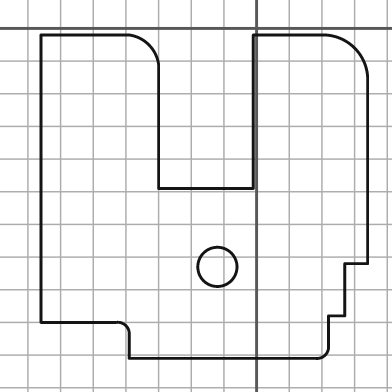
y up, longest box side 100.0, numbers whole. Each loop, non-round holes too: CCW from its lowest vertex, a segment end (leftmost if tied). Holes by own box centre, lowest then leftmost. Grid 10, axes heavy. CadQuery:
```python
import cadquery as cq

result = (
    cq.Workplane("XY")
    .moveTo(-39.0, -101.0)
    .lineTo(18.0, -101.0)
    .threePointArc((21.0, -100.0), (22.0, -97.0))
    .lineTo(22.0, -88.0)
    .lineTo(27.0, -88.0)
    .lineTo(27.0, -72.0)
    .lineTo(34.0, -72.0)
    .lineTo(34.0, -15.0)
    .threePointArc((30.0, -6.0), (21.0, -2.0))
    .lineTo(-1.0, -2.0)
    .lineTo(-1.0, -49.0)
    .lineTo(-30.0, -49.0)
    .lineTo(-30.0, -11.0)
    .threePointArc((-33.0, -5.0), (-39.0, -2.0))
    .lineTo(-66.0, -2.0)
    .lineTo(-66.0, -90.0)
    .lineTo(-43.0, -90.0)
    .threePointArc((-40.0, -91.0), (-39.0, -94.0))
    .close()
    .moveTo(-12.0, -73.0)
    .circle(6.0)
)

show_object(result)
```